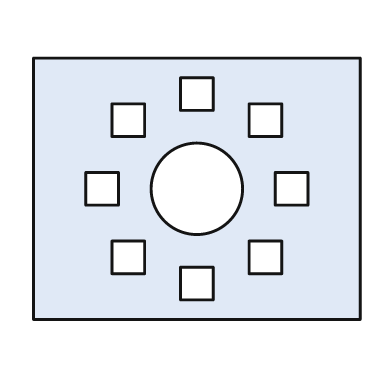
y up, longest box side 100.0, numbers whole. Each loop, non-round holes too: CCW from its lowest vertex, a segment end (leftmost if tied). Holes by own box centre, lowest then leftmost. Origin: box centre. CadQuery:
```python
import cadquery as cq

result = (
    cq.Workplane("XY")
    .moveTo(-50.0, -40.0)
    .lineTo(50.0, -40.0)
    .lineTo(50.0, 40.0)
    .lineTo(-50.0, 40.0)
    .close()
    .moveTo(-5.0, -34.0)
    .lineTo(5.0, -34.0)
    .lineTo(5.0, -24.0)
    .lineTo(-5.0, -24.0)
    .close()
    .moveTo(-26.0, -26.0)
    .lineTo(-16.0, -26.0)
    .lineTo(-16.0, -16.0)
    .lineTo(-26.0, -16.0)
    .close()
    .moveTo(16.0, -26.0)
    .lineTo(26.0, -26.0)
    .lineTo(26.0, -16.0)
    .lineTo(16.0, -16.0)
    .close()
    .moveTo(-34.0, -5.0)
    .lineTo(-24.0, -5.0)
    .lineTo(-24.0, 5.0)
    .lineTo(-34.0, 5.0)
    .close()
    .moveTo(0.0, 0.0)
    .circle(14.0)
    .moveTo(24.0, -5.0)
    .lineTo(34.0, -5.0)
    .lineTo(34.0, 5.0)
    .lineTo(24.0, 5.0)
    .close()
    .moveTo(-26.0, 16.0)
    .lineTo(-16.0, 16.0)
    .lineTo(-16.0, 26.0)
    .lineTo(-26.0, 26.0)
    .close()
    .moveTo(16.0, 16.0)
    .lineTo(26.0, 16.0)
    .lineTo(26.0, 26.0)
    .lineTo(16.0, 26.0)
    .close()
    .moveTo(-5.0, 24.0)
    .lineTo(5.0, 24.0)
    .lineTo(5.0, 34.0)
    .lineTo(-5.0, 34.0)
    .close()
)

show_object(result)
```